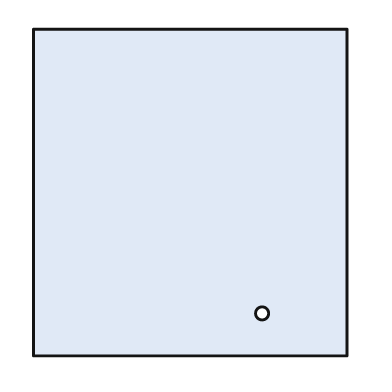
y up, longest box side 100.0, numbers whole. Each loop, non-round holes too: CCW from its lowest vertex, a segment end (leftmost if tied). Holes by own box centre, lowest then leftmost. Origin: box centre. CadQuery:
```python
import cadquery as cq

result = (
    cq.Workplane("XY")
    .moveTo(-48.0, -50.0)
    .lineTo(48.0, -50.0)
    .lineTo(48.0, 50.0)
    .lineTo(-48.0, 50.0)
    .close()
    .moveTo(22.0, -37.0)
    .circle(2.0)
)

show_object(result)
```